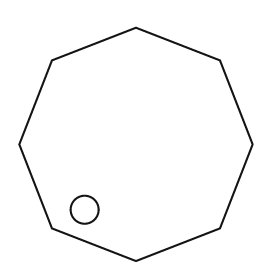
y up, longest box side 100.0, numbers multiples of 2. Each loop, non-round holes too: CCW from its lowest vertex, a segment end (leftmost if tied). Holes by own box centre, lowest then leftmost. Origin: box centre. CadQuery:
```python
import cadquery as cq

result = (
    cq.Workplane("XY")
    .moveTo(0.0, -50.0)
    .lineTo(36.0, -36.0)
    .lineTo(50.0, 0.0)
    .lineTo(36.0, 36.0)
    .lineTo(0.0, 50.0)
    .lineTo(-36.0, 36.0)
    .lineTo(-50.0, 0.0)
    .lineTo(-36.0, -36.0)
    .close()
    .moveTo(-22.0, -28.0)
    .circle(6.0)
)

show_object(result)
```